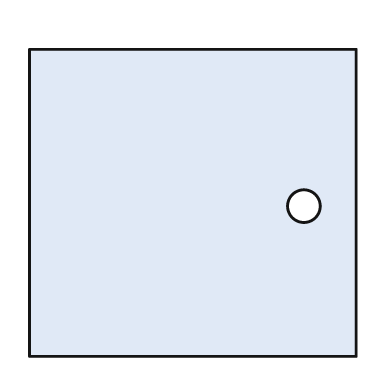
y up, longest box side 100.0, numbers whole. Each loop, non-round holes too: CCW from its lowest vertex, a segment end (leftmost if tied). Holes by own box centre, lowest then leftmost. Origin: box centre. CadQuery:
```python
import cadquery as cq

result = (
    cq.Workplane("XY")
    .moveTo(-50.0, -47.0)
    .lineTo(50.0, -47.0)
    .lineTo(50.0, 47.0)
    .lineTo(-50.0, 47.0)
    .close()
    .moveTo(34.0, -1.0)
    .circle(5.0)
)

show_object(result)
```